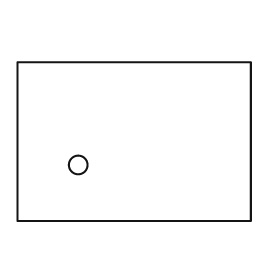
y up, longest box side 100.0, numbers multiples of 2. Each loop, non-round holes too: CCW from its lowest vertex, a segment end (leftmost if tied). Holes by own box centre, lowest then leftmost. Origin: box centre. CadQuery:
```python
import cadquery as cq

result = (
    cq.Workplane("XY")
    .moveTo(-50.0, -34.0)
    .lineTo(50.0, -34.0)
    .lineTo(50.0, 34.0)
    .lineTo(-50.0, 34.0)
    .close()
    .moveTo(-24.0, -10.0)
    .circle(4.0)
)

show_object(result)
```